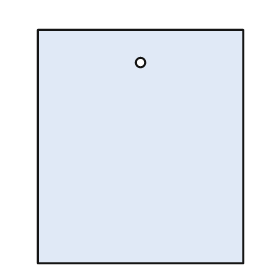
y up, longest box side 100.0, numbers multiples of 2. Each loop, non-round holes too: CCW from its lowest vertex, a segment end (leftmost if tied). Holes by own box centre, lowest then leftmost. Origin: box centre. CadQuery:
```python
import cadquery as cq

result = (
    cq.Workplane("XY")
    .moveTo(-44.0, -50.0)
    .lineTo(44.0, -50.0)
    .lineTo(44.0, 50.0)
    .lineTo(-44.0, 50.0)
    .close()
    .moveTo(0.0, 36.0)
    .circle(2.0)
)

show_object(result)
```